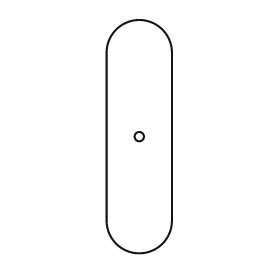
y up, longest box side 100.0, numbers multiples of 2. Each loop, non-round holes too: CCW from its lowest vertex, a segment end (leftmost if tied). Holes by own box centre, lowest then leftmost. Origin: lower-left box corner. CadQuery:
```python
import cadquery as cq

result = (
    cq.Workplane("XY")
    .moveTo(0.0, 14.0)
    .threePointArc((14.0, 0.0), (28.0, 14.0))
    .lineTo(28.0, 86.0)
    .threePointArc((14.0, 100.0), (0.0, 86.0))
    .close()
    .moveTo(14.0, 50.0)
    .circle(2.0)
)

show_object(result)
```